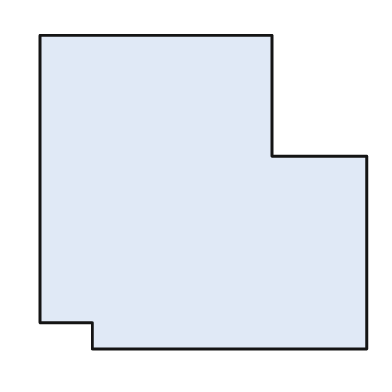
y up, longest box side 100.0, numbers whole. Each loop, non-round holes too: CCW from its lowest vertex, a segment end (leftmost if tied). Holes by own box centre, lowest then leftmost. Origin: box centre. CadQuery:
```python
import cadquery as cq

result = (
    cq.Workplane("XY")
    .moveTo(-34.0, -48.0)
    .lineTo(50.0, -48.0)
    .lineTo(50.0, 11.0)
    .lineTo(21.0, 11.0)
    .lineTo(21.0, 48.0)
    .lineTo(-50.0, 48.0)
    .lineTo(-50.0, -40.0)
    .lineTo(-34.0, -40.0)
    .close()
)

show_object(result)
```